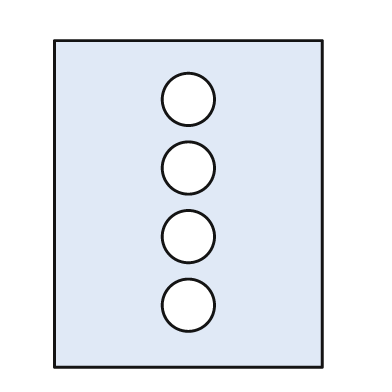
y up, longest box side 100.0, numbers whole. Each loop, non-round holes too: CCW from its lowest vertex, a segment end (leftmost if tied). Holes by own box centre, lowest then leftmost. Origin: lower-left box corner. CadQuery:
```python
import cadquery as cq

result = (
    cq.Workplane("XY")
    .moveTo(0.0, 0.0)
    .lineTo(82.0, 0.0)
    .lineTo(82.0, 100.0)
    .lineTo(0.0, 100.0)
    .close()
    .moveTo(41.0, 19.0)
    .circle(8.0)
    .moveTo(41.0, 40.0)
    .circle(8.0)
    .moveTo(41.0, 61.0)
    .circle(8.0)
    .moveTo(41.0, 82.0)
    .circle(8.0)
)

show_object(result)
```